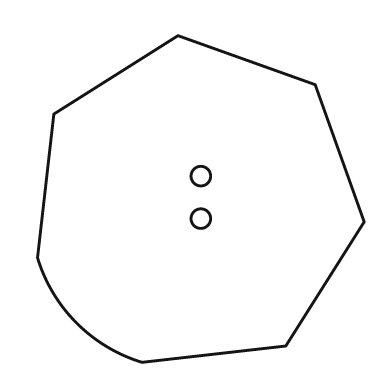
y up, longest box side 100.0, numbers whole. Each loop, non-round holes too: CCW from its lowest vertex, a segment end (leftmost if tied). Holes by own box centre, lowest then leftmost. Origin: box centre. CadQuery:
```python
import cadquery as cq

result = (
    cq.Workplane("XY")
    .moveTo(-18.0, -50.0)
    .lineTo(26.0, -45.0)
    .lineTo(50.0, -7.0)
    .lineTo(35.0, 35.0)
    .lineTo(-7.0, 50.0)
    .lineTo(-45.0, 26.0)
    .lineTo(-50.0, -18.0)
    .threePointArc((-38.0, -38.0), (-18.0, -50.0))
    .close()
    .moveTo(0.0, -6.0)
    .circle(3.0)
    .moveTo(0.0, 7.0)
    .circle(3.0)
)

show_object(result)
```